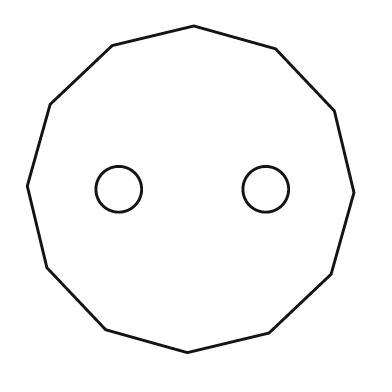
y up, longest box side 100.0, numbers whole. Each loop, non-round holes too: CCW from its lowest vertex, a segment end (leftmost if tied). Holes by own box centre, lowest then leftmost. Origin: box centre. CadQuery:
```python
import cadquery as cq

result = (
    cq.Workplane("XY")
    .moveTo(-1.0, -50.0)
    .lineTo(24.0, -44.0)
    .lineTo(43.0, -26.0)
    .lineTo(50.0, -1.0)
    .lineTo(44.0, 24.0)
    .lineTo(26.0, 43.0)
    .lineTo(1.0, 50.0)
    .lineTo(-24.0, 44.0)
    .lineTo(-43.0, 26.0)
    .lineTo(-50.0, 1.0)
    .lineTo(-44.0, -24.0)
    .lineTo(-26.0, -43.0)
    .close()
    .moveTo(-22.0, 0.0)
    .circle(7.0)
    .moveTo(23.0, 0.0)
    .circle(7.0)
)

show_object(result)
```